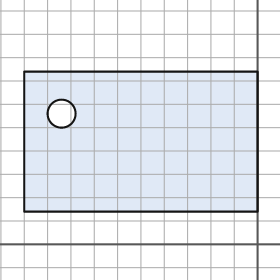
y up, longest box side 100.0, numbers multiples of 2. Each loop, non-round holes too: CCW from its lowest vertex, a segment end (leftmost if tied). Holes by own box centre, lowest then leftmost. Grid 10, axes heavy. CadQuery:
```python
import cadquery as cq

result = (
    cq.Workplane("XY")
    .moveTo(-100.0, 14.0)
    .lineTo(0.0, 14.0)
    .lineTo(0.0, 74.0)
    .lineTo(-100.0, 74.0)
    .close()
    .moveTo(-84.0, 56.0)
    .circle(6.0)
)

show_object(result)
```